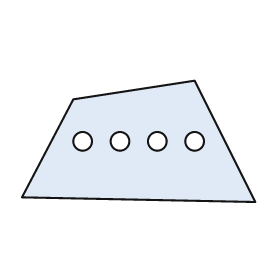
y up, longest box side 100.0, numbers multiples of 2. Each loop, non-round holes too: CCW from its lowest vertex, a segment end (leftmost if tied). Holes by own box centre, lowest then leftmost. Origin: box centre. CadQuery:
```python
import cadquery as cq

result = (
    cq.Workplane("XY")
    .moveTo(50.0, -26.0)
    .lineTo(24.0, 26.0)
    .lineTo(-28.0, 18.0)
    .lineTo(-50.0, -24.0)
    .close()
    .moveTo(-24.0, 0.0)
    .circle(4.0)
    .moveTo(-8.0, 0.0)
    .circle(4.0)
    .moveTo(8.0, 0.0)
    .circle(4.0)
    .moveTo(24.0, 0.0)
    .circle(4.0)
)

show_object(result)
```